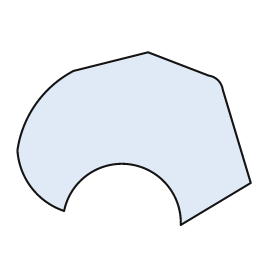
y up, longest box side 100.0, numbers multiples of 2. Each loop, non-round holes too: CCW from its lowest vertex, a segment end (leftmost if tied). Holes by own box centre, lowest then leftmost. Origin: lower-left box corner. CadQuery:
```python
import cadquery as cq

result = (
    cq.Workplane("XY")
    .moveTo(70.0, 0.0)
    .lineTo(100.0, 18.0)
    .lineTo(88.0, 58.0)
    .threePointArc((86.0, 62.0), (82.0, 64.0))
    .lineTo(56.0, 74.0)
    .lineTo(24.0, 66.0)
    .threePointArc((8.0, 52.0), (0.0, 32.0))
    .threePointArc((6.0, 16.0), (20.0, 6.0))
    .threePointArc((48.0, 26.0), (70.0, 0.0))
    .close()
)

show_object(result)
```